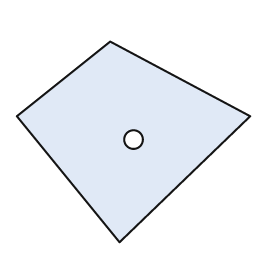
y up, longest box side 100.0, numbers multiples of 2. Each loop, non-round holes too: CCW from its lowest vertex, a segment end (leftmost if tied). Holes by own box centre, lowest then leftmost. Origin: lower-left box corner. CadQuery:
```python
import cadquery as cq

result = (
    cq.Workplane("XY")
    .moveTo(44.0, 0.0)
    .lineTo(100.0, 54.0)
    .lineTo(40.0, 86.0)
    .lineTo(0.0, 54.0)
    .close()
    .moveTo(50.0, 44.0)
    .circle(4.0)
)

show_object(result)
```